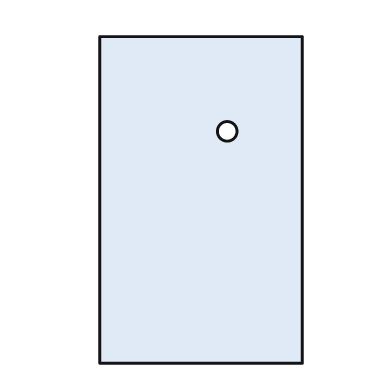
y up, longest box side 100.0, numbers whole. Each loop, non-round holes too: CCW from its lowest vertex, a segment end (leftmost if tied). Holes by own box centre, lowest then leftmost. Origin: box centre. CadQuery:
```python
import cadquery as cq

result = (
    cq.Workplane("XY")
    .moveTo(-31.0, -50.0)
    .lineTo(31.0, -50.0)
    .lineTo(31.0, 50.0)
    .lineTo(-31.0, 50.0)
    .close()
    .moveTo(8.0, 21.0)
    .circle(3.0)
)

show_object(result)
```